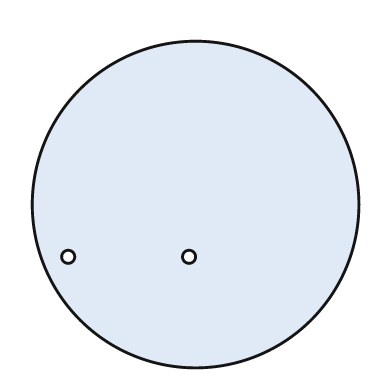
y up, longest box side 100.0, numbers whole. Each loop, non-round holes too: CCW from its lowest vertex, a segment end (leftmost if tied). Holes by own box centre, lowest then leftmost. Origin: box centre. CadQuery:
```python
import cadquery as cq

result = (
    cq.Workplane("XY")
    .moveTo(0.0, 0.0)
    .circle(50.0)
    .moveTo(-39.0, -16.0)
    .circle(2.0)
    .moveTo(-2.0, -16.0)
    .circle(2.0)
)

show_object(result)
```